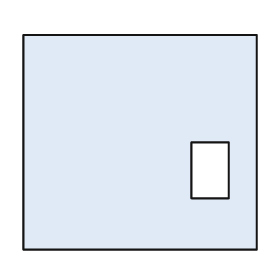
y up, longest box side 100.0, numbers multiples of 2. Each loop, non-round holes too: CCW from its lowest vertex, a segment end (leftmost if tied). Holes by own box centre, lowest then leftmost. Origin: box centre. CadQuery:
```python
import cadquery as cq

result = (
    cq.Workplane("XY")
    .moveTo(-50.0, -46.0)
    .lineTo(50.0, -46.0)
    .lineTo(50.0, 46.0)
    .lineTo(-50.0, 46.0)
    .close()
    .moveTo(22.0, -24.0)
    .lineTo(38.0, -24.0)
    .lineTo(38.0, 0.0)
    .lineTo(22.0, 0.0)
    .close()
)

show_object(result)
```